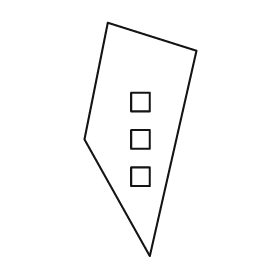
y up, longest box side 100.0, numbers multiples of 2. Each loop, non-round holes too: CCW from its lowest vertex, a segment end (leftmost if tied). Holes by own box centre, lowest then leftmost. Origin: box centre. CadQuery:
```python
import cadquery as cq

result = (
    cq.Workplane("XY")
    .moveTo(4.0, -50.0)
    .lineTo(24.0, 38.0)
    .lineTo(-14.0, 50.0)
    .lineTo(-24.0, 0.0)
    .close()
    .moveTo(-4.0, -20.0)
    .lineTo(4.0, -20.0)
    .lineTo(4.0, -12.0)
    .lineTo(-4.0, -12.0)
    .close()
    .moveTo(-4.0, -4.0)
    .lineTo(4.0, -4.0)
    .lineTo(4.0, 4.0)
    .lineTo(-4.0, 4.0)
    .close()
    .moveTo(-4.0, 12.0)
    .lineTo(4.0, 12.0)
    .lineTo(4.0, 20.0)
    .lineTo(-4.0, 20.0)
    .close()
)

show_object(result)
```